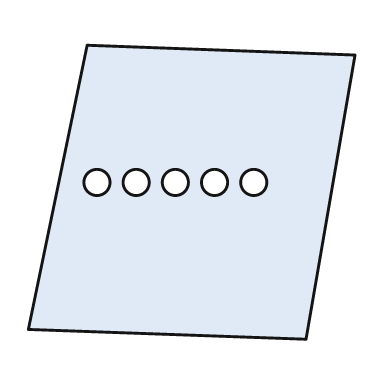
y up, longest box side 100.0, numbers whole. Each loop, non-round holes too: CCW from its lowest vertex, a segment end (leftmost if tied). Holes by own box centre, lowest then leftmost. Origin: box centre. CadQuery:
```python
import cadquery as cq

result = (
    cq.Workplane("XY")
    .moveTo(35.0, -45.0)
    .lineTo(50.0, 42.0)
    .lineTo(-32.0, 45.0)
    .lineTo(-50.0, -42.0)
    .close()
    .moveTo(-29.0, 3.0)
    .circle(4.0)
    .moveTo(-17.0, 3.0)
    .circle(4.0)
    .moveTo(-5.0, 3.0)
    .circle(4.0)
    .moveTo(7.0, 3.0)
    .circle(4.0)
    .moveTo(19.0, 3.0)
    .circle(4.0)
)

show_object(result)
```